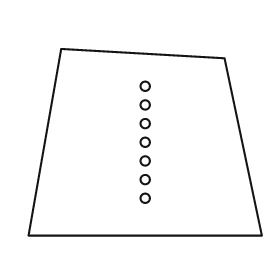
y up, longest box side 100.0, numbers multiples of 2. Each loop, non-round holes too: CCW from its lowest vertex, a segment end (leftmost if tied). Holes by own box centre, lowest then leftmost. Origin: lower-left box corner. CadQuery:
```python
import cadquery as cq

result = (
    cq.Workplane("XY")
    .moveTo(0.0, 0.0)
    .lineTo(100.0, 0.0)
    .lineTo(84.0, 76.0)
    .lineTo(14.0, 80.0)
    .close()
    .moveTo(50.0, 16.0)
    .circle(2.0)
    .moveTo(50.0, 24.0)
    .circle(2.0)
    .moveTo(50.0, 32.0)
    .circle(2.0)
    .moveTo(50.0, 40.0)
    .circle(2.0)
    .moveTo(50.0, 48.0)
    .circle(2.0)
    .moveTo(50.0, 56.0)
    .circle(2.0)
    .moveTo(50.0, 64.0)
    .circle(2.0)
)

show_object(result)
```